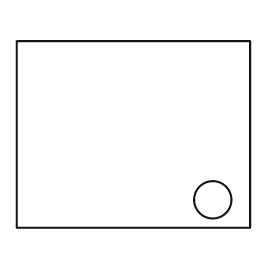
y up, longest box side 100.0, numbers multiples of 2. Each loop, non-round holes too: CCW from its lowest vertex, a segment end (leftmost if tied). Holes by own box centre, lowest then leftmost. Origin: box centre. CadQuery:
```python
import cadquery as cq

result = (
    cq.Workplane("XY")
    .moveTo(-50.0, -40.0)
    .lineTo(50.0, -40.0)
    .lineTo(50.0, 40.0)
    .lineTo(-50.0, 40.0)
    .close()
    .moveTo(34.0, -28.0)
    .circle(8.0)
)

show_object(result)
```